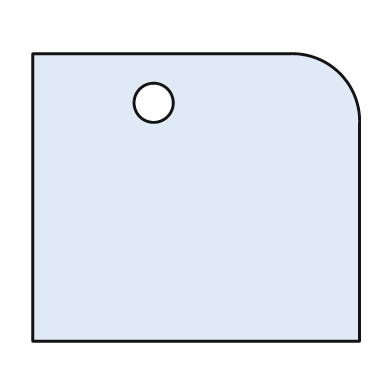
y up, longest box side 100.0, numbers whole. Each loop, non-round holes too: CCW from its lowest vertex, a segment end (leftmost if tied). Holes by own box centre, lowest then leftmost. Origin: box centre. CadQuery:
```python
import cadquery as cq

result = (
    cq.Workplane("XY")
    .moveTo(-50.0, -44.0)
    .lineTo(50.0, -44.0)
    .lineTo(50.0, 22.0)
    .threePointArc((44.0, 38.0), (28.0, 44.0))
    .lineTo(-50.0, 44.0)
    .close()
    .moveTo(-13.0, 29.0)
    .circle(6.0)
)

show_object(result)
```